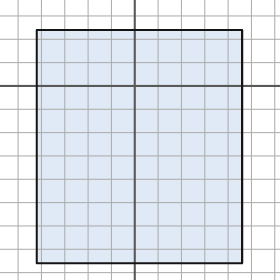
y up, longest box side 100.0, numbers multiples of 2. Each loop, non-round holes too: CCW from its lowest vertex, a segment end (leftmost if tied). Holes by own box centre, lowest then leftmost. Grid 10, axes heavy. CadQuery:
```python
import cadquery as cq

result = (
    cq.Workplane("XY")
    .moveTo(-42.0, -76.0)
    .lineTo(46.0, -76.0)
    .lineTo(46.0, 24.0)
    .lineTo(-42.0, 24.0)
    .close()
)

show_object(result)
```